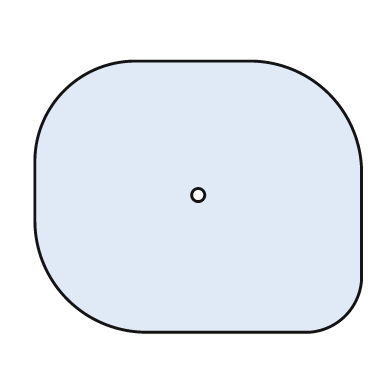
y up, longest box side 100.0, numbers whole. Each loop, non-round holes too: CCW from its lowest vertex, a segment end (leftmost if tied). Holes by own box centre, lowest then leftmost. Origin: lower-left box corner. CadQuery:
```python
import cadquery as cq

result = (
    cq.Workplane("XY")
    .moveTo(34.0, 0.0)
    .lineTo(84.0, 0.0)
    .threePointArc((95.0, 5.0), (100.0, 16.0))
    .lineTo(100.0, 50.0)
    .threePointArc((90.0, 73.0), (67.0, 83.0))
    .lineTo(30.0, 83.0)
    .threePointArc((9.0, 74.0), (0.0, 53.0))
    .lineTo(0.0, 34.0)
    .threePointArc((10.0, 10.0), (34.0, 0.0))
    .close()
    .moveTo(50.0, 42.0)
    .circle(2.0)
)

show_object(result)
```